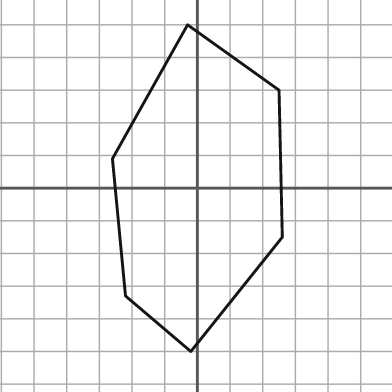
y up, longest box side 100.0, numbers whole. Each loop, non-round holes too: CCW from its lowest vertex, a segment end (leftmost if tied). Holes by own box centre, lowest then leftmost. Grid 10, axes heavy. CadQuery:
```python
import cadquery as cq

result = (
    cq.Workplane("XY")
    .moveTo(-2.0, -50.0)
    .lineTo(26.0, -15.0)
    .lineTo(25.0, 30.0)
    .lineTo(-3.0, 50.0)
    .lineTo(-26.0, 9.0)
    .lineTo(-22.0, -33.0)
    .close()
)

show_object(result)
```